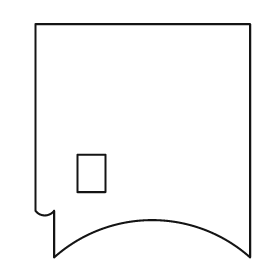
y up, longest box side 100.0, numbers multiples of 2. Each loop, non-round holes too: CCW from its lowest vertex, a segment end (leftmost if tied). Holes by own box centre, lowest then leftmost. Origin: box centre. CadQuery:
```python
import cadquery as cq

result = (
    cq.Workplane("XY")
    .moveTo(-38.0, -50.0)
    .threePointArc((4.0, -34.0), (46.0, -50.0))
    .lineTo(46.0, 50.0)
    .lineTo(-46.0, 50.0)
    .lineTo(-46.0, -30.0)
    .threePointArc((-42.0, -32.0), (-38.0, -30.0))
    .close()
    .moveTo(-28.0, -22.0)
    .lineTo(-16.0, -22.0)
    .lineTo(-16.0, -6.0)
    .lineTo(-28.0, -6.0)
    .close()
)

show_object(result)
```